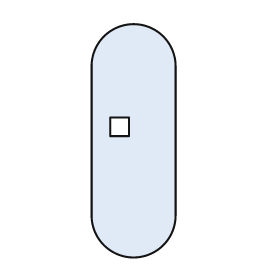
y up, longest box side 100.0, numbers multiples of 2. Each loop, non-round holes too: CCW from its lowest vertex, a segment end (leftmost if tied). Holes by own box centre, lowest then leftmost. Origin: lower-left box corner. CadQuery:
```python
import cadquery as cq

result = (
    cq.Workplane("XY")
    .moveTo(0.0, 18.0)
    .threePointArc((18.0, 0.0), (36.0, 18.0))
    .lineTo(36.0, 82.0)
    .threePointArc((18.0, 100.0), (0.0, 82.0))
    .close()
    .moveTo(8.0, 52.0)
    .lineTo(16.0, 52.0)
    .lineTo(16.0, 60.0)
    .lineTo(8.0, 60.0)
    .close()
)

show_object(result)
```